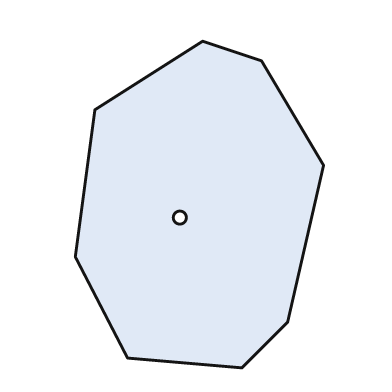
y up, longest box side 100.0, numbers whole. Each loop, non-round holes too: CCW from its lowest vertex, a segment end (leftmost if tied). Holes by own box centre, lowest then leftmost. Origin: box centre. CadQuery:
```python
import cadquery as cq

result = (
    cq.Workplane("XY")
    .moveTo(13.0, -50.0)
    .lineTo(27.0, -36.0)
    .lineTo(38.0, 12.0)
    .lineTo(19.0, 44.0)
    .lineTo(1.0, 50.0)
    .lineTo(-32.0, 29.0)
    .lineTo(-38.0, -16.0)
    .lineTo(-22.0, -47.0)
    .close()
    .moveTo(-6.0, -4.0)
    .circle(2.0)
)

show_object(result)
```